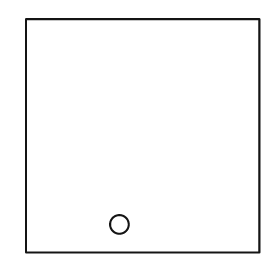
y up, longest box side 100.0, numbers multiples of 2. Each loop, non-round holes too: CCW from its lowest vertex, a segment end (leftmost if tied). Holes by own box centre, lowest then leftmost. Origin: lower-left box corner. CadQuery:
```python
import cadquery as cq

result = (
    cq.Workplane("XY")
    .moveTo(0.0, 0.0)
    .lineTo(100.0, 0.0)
    .lineTo(100.0, 100.0)
    .lineTo(0.0, 100.0)
    .close()
    .moveTo(40.0, 12.0)
    .circle(4.0)
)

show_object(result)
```